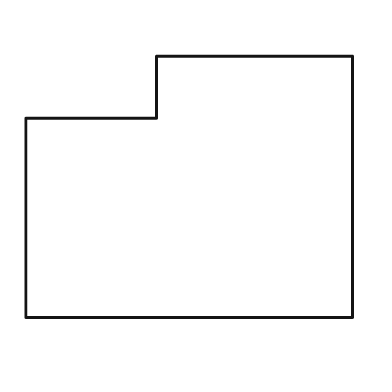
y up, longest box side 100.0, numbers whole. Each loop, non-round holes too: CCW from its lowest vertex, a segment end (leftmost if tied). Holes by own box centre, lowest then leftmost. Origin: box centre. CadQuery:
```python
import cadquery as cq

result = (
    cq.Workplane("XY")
    .moveTo(-50.0, -40.0)
    .lineTo(50.0, -40.0)
    .lineTo(50.0, 40.0)
    .lineTo(-10.0, 40.0)
    .lineTo(-10.0, 21.0)
    .lineTo(-50.0, 21.0)
    .close()
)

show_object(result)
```